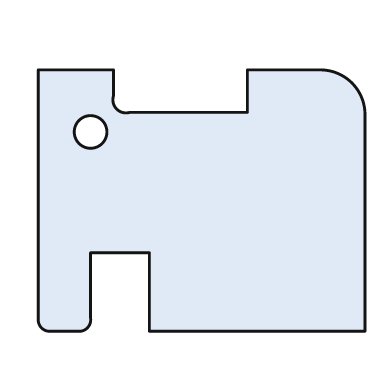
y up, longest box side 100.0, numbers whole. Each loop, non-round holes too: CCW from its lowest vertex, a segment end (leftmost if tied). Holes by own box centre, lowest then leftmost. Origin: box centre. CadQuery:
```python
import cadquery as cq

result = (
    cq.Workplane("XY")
    .moveTo(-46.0, -40.0)
    .lineTo(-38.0, -40.0)
    .threePointArc((-35.0, -39.0), (-34.0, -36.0))
    .lineTo(-34.0, -16.0)
    .lineTo(-16.0, -16.0)
    .lineTo(-16.0, -40.0)
    .lineTo(50.0, -40.0)
    .lineTo(50.0, 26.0)
    .threePointArc((46.0, 36.0), (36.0, 40.0))
    .lineTo(14.0, 40.0)
    .lineTo(14.0, 27.0)
    .lineTo(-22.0, 27.0)
    .threePointArc((-26.0, 28.0), (-27.0, 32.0))
    .lineTo(-27.0, 40.0)
    .lineTo(-50.0, 40.0)
    .lineTo(-50.0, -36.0)
    .threePointArc((-49.0, -39.0), (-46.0, -40.0))
    .close()
    .moveTo(-34.0, 21.0)
    .circle(5.0)
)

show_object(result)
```